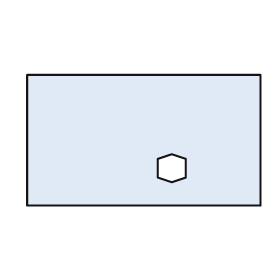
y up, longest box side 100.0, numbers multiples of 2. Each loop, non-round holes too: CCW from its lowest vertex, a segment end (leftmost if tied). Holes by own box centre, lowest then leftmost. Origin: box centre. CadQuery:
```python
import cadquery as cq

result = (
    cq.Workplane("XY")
    .moveTo(-50.0, -28.0)
    .lineTo(50.0, -28.0)
    .lineTo(50.0, 28.0)
    .lineTo(-50.0, 28.0)
    .close()
    .moveTo(12.0, -18.0)
    .lineTo(18.0, -16.0)
    .lineTo(18.0, -8.0)
    .lineTo(12.0, -6.0)
    .lineTo(6.0, -8.0)
    .lineTo(6.0, -16.0)
    .close()
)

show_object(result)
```